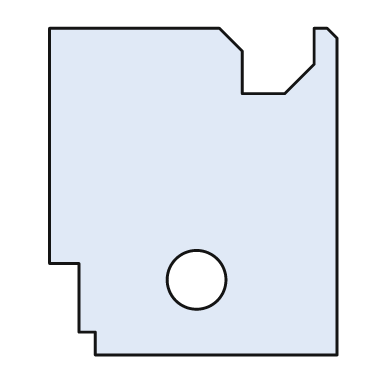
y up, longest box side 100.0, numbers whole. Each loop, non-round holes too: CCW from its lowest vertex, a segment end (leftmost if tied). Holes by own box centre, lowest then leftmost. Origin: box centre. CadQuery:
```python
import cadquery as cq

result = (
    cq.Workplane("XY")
    .moveTo(-30.0, -50.0)
    .lineTo(44.0, -50.0)
    .lineTo(44.0, 47.0)
    .lineTo(41.0, 50.0)
    .lineTo(37.0, 50.0)
    .lineTo(37.0, 39.0)
    .lineTo(28.0, 30.0)
    .lineTo(15.0, 30.0)
    .lineTo(15.0, 43.0)
    .lineTo(8.0, 50.0)
    .lineTo(-44.0, 50.0)
    .lineTo(-44.0, -22.0)
    .lineTo(-35.0, -22.0)
    .lineTo(-35.0, -43.0)
    .lineTo(-30.0, -43.0)
    .close()
    .moveTo(1.0, -27.0)
    .circle(9.0)
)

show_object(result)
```